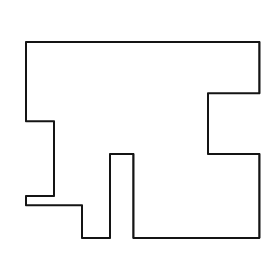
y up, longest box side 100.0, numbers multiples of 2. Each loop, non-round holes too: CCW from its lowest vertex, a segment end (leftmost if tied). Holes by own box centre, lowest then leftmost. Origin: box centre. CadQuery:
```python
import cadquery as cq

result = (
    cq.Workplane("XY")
    .moveTo(-26.0, -42.0)
    .lineTo(-14.0, -42.0)
    .lineTo(-14.0, -6.0)
    .lineTo(-4.0, -6.0)
    .lineTo(-4.0, -42.0)
    .lineTo(50.0, -42.0)
    .lineTo(50.0, -6.0)
    .lineTo(28.0, -6.0)
    .lineTo(28.0, 20.0)
    .lineTo(50.0, 20.0)
    .lineTo(50.0, 42.0)
    .lineTo(-50.0, 42.0)
    .lineTo(-50.0, 8.0)
    .lineTo(-38.0, 8.0)
    .lineTo(-38.0, -24.0)
    .lineTo(-50.0, -24.0)
    .lineTo(-50.0, -28.0)
    .lineTo(-26.0, -28.0)
    .close()
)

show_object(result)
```